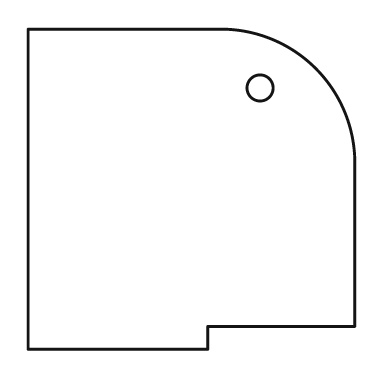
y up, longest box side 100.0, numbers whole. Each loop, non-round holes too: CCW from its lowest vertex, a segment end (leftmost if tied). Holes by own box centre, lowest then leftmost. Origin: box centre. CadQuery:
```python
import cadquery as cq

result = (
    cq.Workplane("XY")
    .moveTo(-50.0, -49.0)
    .lineTo(5.0, -49.0)
    .lineTo(5.0, -42.0)
    .lineTo(50.0, -42.0)
    .lineTo(50.0, 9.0)
    .threePointArc((38.0, 37.0), (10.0, 49.0))
    .lineTo(-50.0, 49.0)
    .close()
    .moveTo(21.0, 31.0)
    .circle(4.0)
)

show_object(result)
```